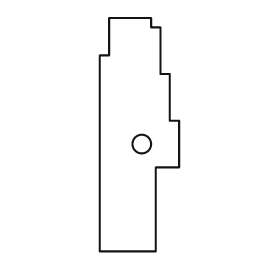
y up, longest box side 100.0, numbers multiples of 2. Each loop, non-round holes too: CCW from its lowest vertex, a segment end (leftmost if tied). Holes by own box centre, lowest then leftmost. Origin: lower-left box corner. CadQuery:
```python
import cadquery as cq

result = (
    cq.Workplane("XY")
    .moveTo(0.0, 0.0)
    .lineTo(24.0, 0.0)
    .lineTo(24.0, 36.0)
    .lineTo(34.0, 36.0)
    .lineTo(34.0, 56.0)
    .lineTo(30.0, 56.0)
    .lineTo(30.0, 76.0)
    .lineTo(26.0, 76.0)
    .lineTo(26.0, 96.0)
    .lineTo(22.0, 96.0)
    .lineTo(22.0, 100.0)
    .lineTo(4.0, 100.0)
    .lineTo(4.0, 84.0)
    .lineTo(0.0, 84.0)
    .close()
    .moveTo(18.0, 46.0)
    .circle(4.0)
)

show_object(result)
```